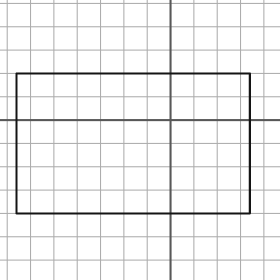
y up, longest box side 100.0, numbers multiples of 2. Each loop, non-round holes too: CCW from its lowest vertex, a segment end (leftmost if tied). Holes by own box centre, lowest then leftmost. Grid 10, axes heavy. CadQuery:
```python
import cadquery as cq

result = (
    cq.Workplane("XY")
    .moveTo(-66.0, -40.0)
    .lineTo(34.0, -40.0)
    .lineTo(34.0, 20.0)
    .lineTo(-66.0, 20.0)
    .close()
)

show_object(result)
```